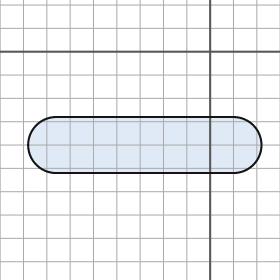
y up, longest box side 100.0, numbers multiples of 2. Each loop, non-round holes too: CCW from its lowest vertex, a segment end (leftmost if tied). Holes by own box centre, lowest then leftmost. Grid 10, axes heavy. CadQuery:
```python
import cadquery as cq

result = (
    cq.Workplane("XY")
    .moveTo(-66.0, -52.0)
    .lineTo(10.0, -52.0)
    .threePointArc((22.0, -40.0), (10.0, -28.0))
    .lineTo(-66.0, -28.0)
    .threePointArc((-78.0, -40.0), (-66.0, -52.0))
    .close()
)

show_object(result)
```